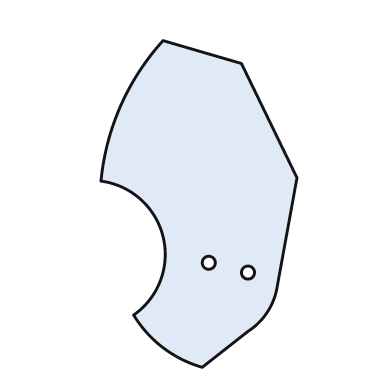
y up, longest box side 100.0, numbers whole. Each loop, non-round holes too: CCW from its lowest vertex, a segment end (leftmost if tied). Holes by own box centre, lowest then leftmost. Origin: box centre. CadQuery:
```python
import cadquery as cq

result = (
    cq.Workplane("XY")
    .moveTo(1.0, -50.0)
    .lineTo(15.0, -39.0)
    .threePointArc((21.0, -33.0), (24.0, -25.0))
    .lineTo(30.0, 8.0)
    .lineTo(13.0, 43.0)
    .lineTo(-11.0, 50.0)
    .threePointArc((-24.0, 30.0), (-30.0, 7.0))
    .threePointArc((-11.0, -10.0), (-20.0, -34.0))
    .threePointArc((-11.0, -44.0), (1.0, -50.0))
    .close()
    .moveTo(15.0, -21.0)
    .circle(2.0)
    .moveTo(3.0, -18.0)
    .circle(2.0)
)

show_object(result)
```